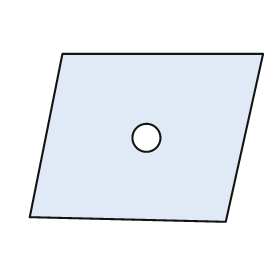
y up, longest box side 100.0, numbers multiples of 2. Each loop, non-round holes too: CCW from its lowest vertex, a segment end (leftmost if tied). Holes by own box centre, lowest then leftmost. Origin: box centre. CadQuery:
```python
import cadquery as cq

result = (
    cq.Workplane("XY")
    .moveTo(34.0, -36.0)
    .lineTo(50.0, 36.0)
    .lineTo(-36.0, 36.0)
    .lineTo(-50.0, -34.0)
    .close()
    .moveTo(0.0, 0.0)
    .circle(6.0)
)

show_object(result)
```